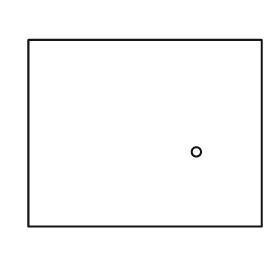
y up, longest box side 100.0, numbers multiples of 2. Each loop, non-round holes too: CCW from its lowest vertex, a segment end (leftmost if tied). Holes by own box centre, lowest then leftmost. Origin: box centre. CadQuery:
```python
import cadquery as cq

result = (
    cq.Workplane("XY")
    .moveTo(-50.0, -40.0)
    .lineTo(50.0, -40.0)
    .lineTo(50.0, 40.0)
    .lineTo(-50.0, 40.0)
    .close()
    .moveTo(22.0, -8.0)
    .circle(2.0)
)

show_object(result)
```